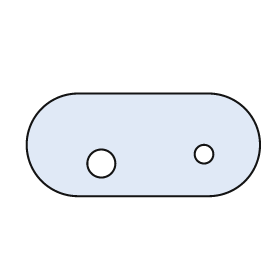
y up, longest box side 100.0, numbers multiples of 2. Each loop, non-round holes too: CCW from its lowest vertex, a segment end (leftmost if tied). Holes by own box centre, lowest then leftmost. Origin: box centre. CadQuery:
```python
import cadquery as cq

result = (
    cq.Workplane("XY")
    .moveTo(-28.0, -22.0)
    .lineTo(28.0, -22.0)
    .threePointArc((50.0, 0.0), (28.0, 22.0))
    .lineTo(-28.0, 22.0)
    .threePointArc((-50.0, 0.0), (-28.0, -22.0))
    .close()
    .moveTo(-18.0, -8.0)
    .circle(6.0)
    .moveTo(26.0, -4.0)
    .circle(4.0)
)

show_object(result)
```